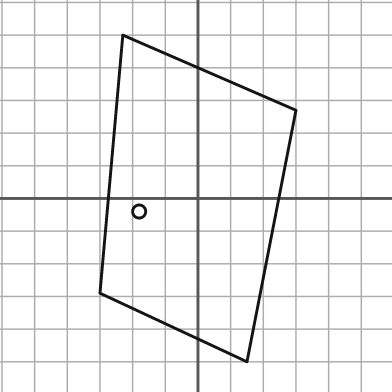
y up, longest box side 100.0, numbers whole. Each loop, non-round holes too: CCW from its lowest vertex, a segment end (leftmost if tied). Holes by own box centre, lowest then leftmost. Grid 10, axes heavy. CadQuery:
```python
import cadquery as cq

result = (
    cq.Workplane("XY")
    .moveTo(15.0, -50.0)
    .lineTo(30.0, 27.0)
    .lineTo(-23.0, 50.0)
    .lineTo(-30.0, -29.0)
    .close()
    .moveTo(-18.0, -4.0)
    .circle(2.0)
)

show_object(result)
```